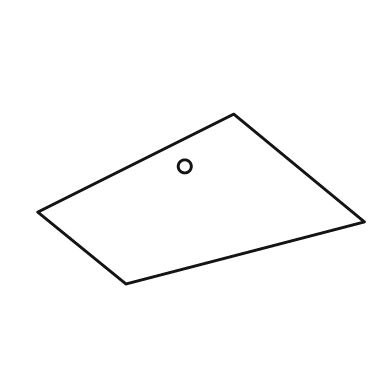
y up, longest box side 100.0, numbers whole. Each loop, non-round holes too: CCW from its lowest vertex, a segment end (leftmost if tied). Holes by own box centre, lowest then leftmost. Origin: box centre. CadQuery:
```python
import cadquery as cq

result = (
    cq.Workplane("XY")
    .moveTo(-23.0, -26.0)
    .lineTo(50.0, -7.0)
    .lineTo(10.0, 26.0)
    .lineTo(-50.0, -4.0)
    .close()
    .moveTo(-5.0, 10.0)
    .circle(2.0)
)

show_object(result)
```